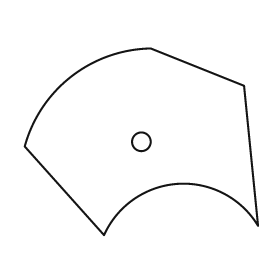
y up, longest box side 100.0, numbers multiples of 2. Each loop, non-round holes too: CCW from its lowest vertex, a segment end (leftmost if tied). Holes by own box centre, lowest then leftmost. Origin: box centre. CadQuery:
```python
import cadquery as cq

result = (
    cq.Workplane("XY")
    .moveTo(-16.0, -40.0)
    .threePointArc((16.0, -18.0), (50.0, -36.0))
    .lineTo(44.0, 24.0)
    .lineTo(4.0, 40.0)
    .threePointArc((-30.0, 28.0), (-50.0, -2.0))
    .close()
    .moveTo(0.0, 0.0)
    .circle(4.0)
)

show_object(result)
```